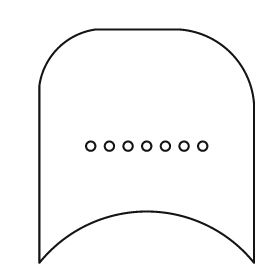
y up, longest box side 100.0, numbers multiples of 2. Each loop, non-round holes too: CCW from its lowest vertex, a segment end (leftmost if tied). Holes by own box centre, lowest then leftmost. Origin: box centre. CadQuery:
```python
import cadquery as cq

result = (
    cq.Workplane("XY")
    .moveTo(-46.0, -50.0)
    .threePointArc((0.0, -28.0), (46.0, -50.0))
    .lineTo(46.0, 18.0)
    .threePointArc((36.0, 40.0), (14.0, 50.0))
    .lineTo(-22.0, 50.0)
    .threePointArc((-38.0, 42.0), (-46.0, 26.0))
    .close()
    .moveTo(-24.0, 0.0)
    .circle(2.0)
    .moveTo(-16.0, 0.0)
    .circle(2.0)
    .moveTo(-8.0, 0.0)
    .circle(2.0)
    .moveTo(0.0, 0.0)
    .circle(2.0)
    .moveTo(8.0, 0.0)
    .circle(2.0)
    .moveTo(16.0, 0.0)
    .circle(2.0)
    .moveTo(24.0, 0.0)
    .circle(2.0)
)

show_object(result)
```